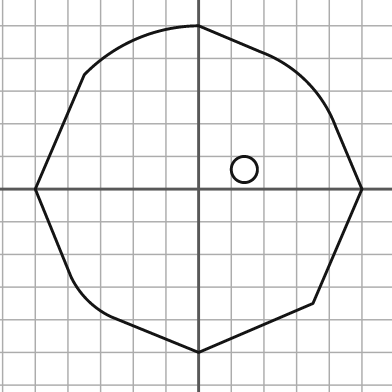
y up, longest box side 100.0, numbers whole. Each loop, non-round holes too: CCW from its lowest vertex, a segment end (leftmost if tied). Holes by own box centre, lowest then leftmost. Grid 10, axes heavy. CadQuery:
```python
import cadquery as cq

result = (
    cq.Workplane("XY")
    .moveTo(0.0, -50.0)
    .lineTo(35.0, -35.0)
    .lineTo(50.0, 0.0)
    .lineTo(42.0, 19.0)
    .threePointArc((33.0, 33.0), (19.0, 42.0))
    .lineTo(0.0, 50.0)
    .threePointArc((-19.0, 46.0), (-35.0, 35.0))
    .lineTo(-50.0, 0.0)
    .lineTo(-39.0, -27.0)
    .threePointArc((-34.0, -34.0), (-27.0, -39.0))
    .close()
    .moveTo(14.0, 6.0)
    .circle(4.0)
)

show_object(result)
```